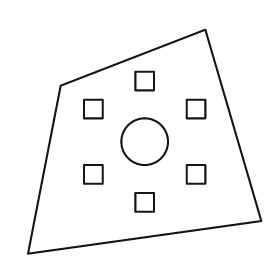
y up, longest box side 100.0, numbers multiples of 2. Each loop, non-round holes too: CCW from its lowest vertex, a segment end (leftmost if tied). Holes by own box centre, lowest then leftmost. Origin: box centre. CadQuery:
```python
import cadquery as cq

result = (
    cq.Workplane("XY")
    .moveTo(-50.0, -48.0)
    .lineTo(50.0, -34.0)
    .lineTo(26.0, 48.0)
    .lineTo(-36.0, 24.0)
    .close()
    .moveTo(-4.0, -30.0)
    .lineTo(4.0, -30.0)
    .lineTo(4.0, -22.0)
    .lineTo(-4.0, -22.0)
    .close()
    .moveTo(-26.0, -18.0)
    .lineTo(-18.0, -18.0)
    .lineTo(-18.0, -10.0)
    .lineTo(-26.0, -10.0)
    .close()
    .moveTo(18.0, -18.0)
    .lineTo(26.0, -18.0)
    .lineTo(26.0, -10.0)
    .lineTo(18.0, -10.0)
    .close()
    .moveTo(0.0, 0.0)
    .circle(10.0)
    .moveTo(-26.0, 10.0)
    .lineTo(-18.0, 10.0)
    .lineTo(-18.0, 18.0)
    .lineTo(-26.0, 18.0)
    .close()
    .moveTo(18.0, 10.0)
    .lineTo(26.0, 10.0)
    .lineTo(26.0, 18.0)
    .lineTo(18.0, 18.0)
    .close()
    .moveTo(-4.0, 22.0)
    .lineTo(4.0, 22.0)
    .lineTo(4.0, 30.0)
    .lineTo(-4.0, 30.0)
    .close()
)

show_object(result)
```